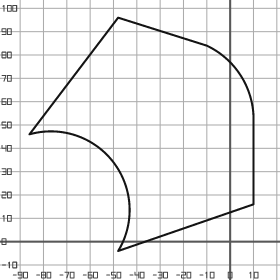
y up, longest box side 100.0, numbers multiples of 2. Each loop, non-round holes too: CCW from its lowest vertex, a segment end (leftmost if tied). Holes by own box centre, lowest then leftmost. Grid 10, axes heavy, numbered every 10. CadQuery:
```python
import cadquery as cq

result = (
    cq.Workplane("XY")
    .moveTo(-48.0, -4.0)
    .lineTo(10.0, 16.0)
    .lineTo(10.0, 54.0)
    .threePointArc((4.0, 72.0), (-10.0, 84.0))
    .lineTo(-48.0, 96.0)
    .lineTo(-86.0, 46.0)
    .threePointArc((-50.0, 34.0), (-48.0, -4.0))
    .close()
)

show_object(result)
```